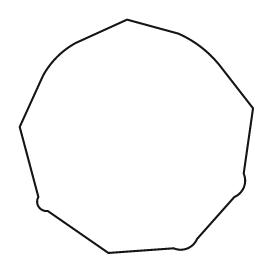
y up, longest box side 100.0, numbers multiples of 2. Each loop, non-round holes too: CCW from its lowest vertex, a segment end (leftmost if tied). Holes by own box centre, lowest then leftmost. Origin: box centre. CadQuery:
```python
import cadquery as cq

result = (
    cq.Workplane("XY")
    .moveTo(-12.0, -50.0)
    .lineTo(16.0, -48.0)
    .threePointArc((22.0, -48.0), (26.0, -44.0))
    .lineTo(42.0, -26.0)
    .threePointArc((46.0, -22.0), (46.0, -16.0))
    .lineTo(50.0, 12.0)
    .lineTo(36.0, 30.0)
    .threePointArc((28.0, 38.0), (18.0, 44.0))
    .lineTo(-4.0, 50.0)
    .lineTo(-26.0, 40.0)
    .threePointArc((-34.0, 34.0), (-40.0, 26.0))
    .lineTo(-50.0, 4.0)
    .lineTo(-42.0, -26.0)
    .threePointArc((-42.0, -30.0), (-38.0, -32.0))
    .close()
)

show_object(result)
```